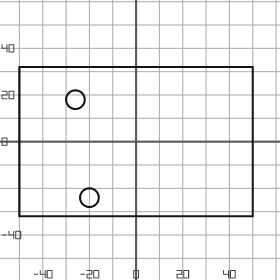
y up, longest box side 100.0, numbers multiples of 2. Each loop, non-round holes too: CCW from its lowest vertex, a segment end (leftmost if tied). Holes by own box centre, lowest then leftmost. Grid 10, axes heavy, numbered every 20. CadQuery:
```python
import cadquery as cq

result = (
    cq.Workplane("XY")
    .moveTo(-50.0, -32.0)
    .lineTo(50.0, -32.0)
    .lineTo(50.0, 32.0)
    .lineTo(-50.0, 32.0)
    .close()
    .moveTo(-20.0, -24.0)
    .circle(4.0)
    .moveTo(-26.0, 18.0)
    .circle(4.0)
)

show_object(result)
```